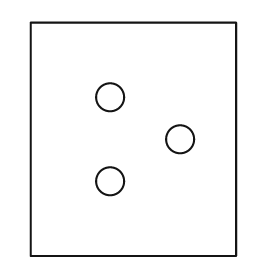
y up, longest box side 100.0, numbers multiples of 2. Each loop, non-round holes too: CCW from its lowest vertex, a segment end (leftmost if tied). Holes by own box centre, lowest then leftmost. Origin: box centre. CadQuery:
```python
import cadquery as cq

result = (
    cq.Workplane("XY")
    .moveTo(-44.0, -50.0)
    .lineTo(44.0, -50.0)
    .lineTo(44.0, 50.0)
    .lineTo(-44.0, 50.0)
    .close()
    .moveTo(-10.0, -18.0)
    .circle(6.0)
    .moveTo(20.0, 0.0)
    .circle(6.0)
    .moveTo(-10.0, 18.0)
    .circle(6.0)
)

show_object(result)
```